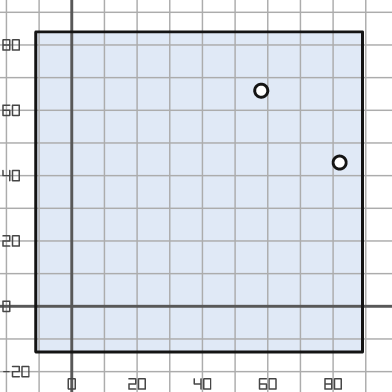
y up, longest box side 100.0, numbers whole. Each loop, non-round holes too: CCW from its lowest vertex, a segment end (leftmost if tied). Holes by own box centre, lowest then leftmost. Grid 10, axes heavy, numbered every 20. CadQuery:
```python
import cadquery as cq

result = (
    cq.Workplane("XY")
    .moveTo(-11.0, -14.0)
    .lineTo(89.0, -14.0)
    .lineTo(89.0, 84.0)
    .lineTo(-11.0, 84.0)
    .close()
    .moveTo(82.0, 44.0)
    .circle(2.0)
    .moveTo(58.0, 66.0)
    .circle(2.0)
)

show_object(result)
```